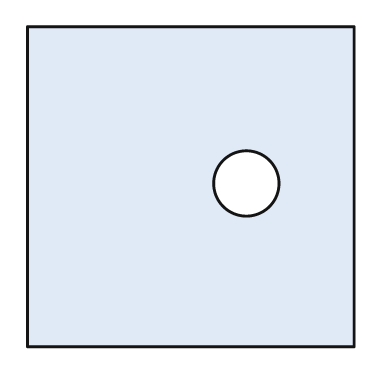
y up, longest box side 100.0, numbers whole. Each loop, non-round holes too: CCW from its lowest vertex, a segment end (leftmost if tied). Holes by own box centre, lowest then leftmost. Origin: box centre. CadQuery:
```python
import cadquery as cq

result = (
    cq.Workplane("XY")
    .moveTo(-50.0, -49.0)
    .lineTo(50.0, -49.0)
    .lineTo(50.0, 49.0)
    .lineTo(-50.0, 49.0)
    .close()
    .moveTo(17.0, 1.0)
    .circle(10.0)
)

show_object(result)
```